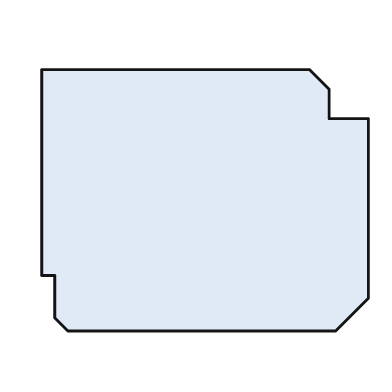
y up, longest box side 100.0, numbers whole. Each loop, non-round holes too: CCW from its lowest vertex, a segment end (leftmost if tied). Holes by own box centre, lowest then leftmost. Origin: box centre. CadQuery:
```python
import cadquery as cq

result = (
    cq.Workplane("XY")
    .moveTo(-42.0, -40.0)
    .lineTo(40.0, -40.0)
    .lineTo(50.0, -30.0)
    .lineTo(50.0, 25.0)
    .lineTo(38.0, 25.0)
    .lineTo(38.0, 34.0)
    .lineTo(32.0, 40.0)
    .lineTo(-50.0, 40.0)
    .lineTo(-50.0, -23.0)
    .lineTo(-46.0, -23.0)
    .lineTo(-46.0, -36.0)
    .close()
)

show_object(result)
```